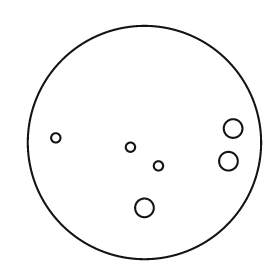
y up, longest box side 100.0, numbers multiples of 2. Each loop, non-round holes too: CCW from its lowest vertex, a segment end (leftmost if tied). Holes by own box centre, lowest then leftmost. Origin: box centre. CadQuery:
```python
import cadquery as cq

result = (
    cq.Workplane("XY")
    .moveTo(0.0, 0.0)
    .circle(50.0)
    .moveTo(0.0, -28.0)
    .circle(4.0)
    .moveTo(6.0, -10.0)
    .circle(2.0)
    .moveTo(36.0, -8.0)
    .circle(4.0)
    .moveTo(-6.0, -2.0)
    .circle(2.0)
    .moveTo(-38.0, 2.0)
    .circle(2.0)
    .moveTo(38.0, 6.0)
    .circle(4.0)
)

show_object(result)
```